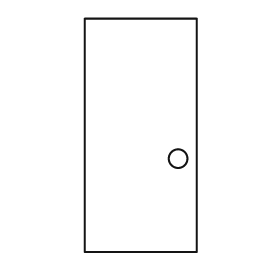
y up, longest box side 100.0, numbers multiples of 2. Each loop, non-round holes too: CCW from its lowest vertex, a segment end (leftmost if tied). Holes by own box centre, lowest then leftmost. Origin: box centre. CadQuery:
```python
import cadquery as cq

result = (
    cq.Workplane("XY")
    .moveTo(-24.0, -50.0)
    .lineTo(24.0, -50.0)
    .lineTo(24.0, 50.0)
    .lineTo(-24.0, 50.0)
    .close()
    .moveTo(16.0, -10.0)
    .circle(4.0)
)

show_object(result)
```